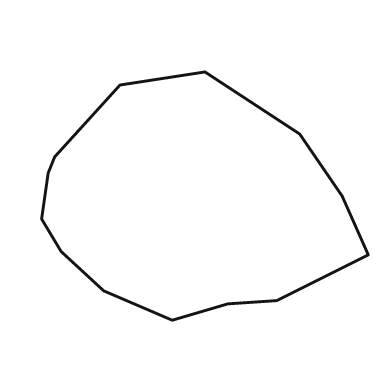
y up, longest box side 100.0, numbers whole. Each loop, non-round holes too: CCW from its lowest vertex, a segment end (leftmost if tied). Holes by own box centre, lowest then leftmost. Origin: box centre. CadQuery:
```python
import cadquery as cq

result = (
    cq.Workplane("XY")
    .moveTo(-10.0, -38.0)
    .lineTo(7.0, -33.0)
    .lineTo(22.0, -32.0)
    .lineTo(50.0, -18.0)
    .lineTo(42.0, 0.0)
    .lineTo(29.0, 19.0)
    .lineTo(0.0, 38.0)
    .lineTo(-26.0, 34.0)
    .lineTo(-46.0, 12.0)
    .lineTo(-48.0, 7.0)
    .lineTo(-50.0, -7.0)
    .lineTo(-44.0, -17.0)
    .lineTo(-31.0, -29.0)
    .close()
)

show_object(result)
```